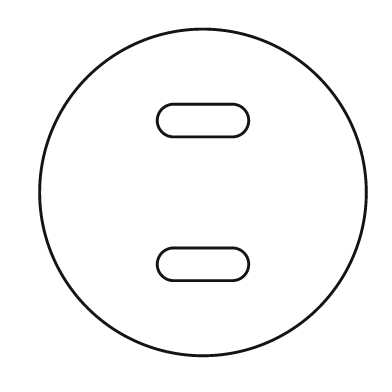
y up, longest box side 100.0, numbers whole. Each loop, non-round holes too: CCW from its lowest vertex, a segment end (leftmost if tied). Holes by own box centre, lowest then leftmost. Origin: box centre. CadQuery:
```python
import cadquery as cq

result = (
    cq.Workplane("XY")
    .moveTo(0.0, 0.0)
    .circle(50.0)
    .moveTo(-9.0, -27.0)
    .lineTo(9.0, -27.0)
    .threePointArc((14.0, -22.0), (9.0, -17.0))
    .lineTo(-9.0, -17.0)
    .threePointArc((-14.0, -22.0), (-9.0, -27.0))
    .close()
    .moveTo(-9.0, 17.0)
    .lineTo(9.0, 17.0)
    .threePointArc((14.0, 22.0), (9.0, 27.0))
    .lineTo(-9.0, 27.0)
    .threePointArc((-14.0, 22.0), (-9.0, 17.0))
    .close()
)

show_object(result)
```